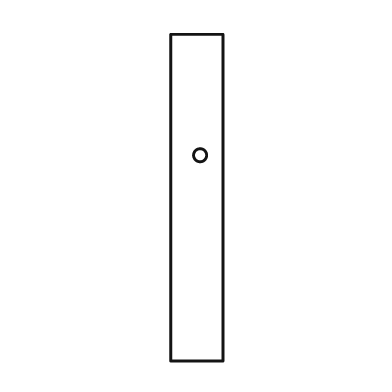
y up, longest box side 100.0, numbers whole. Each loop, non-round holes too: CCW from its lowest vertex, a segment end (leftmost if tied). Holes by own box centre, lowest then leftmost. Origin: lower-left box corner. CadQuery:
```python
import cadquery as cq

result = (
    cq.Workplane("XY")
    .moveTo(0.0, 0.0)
    .lineTo(16.0, 0.0)
    .lineTo(16.0, 100.0)
    .lineTo(0.0, 100.0)
    .close()
    .moveTo(9.0, 63.0)
    .circle(2.0)
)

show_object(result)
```